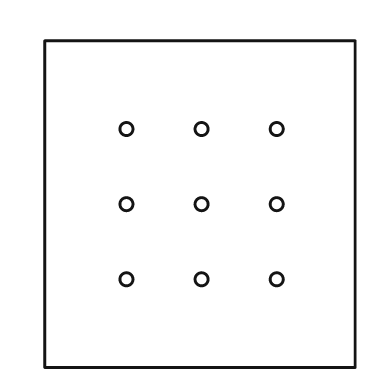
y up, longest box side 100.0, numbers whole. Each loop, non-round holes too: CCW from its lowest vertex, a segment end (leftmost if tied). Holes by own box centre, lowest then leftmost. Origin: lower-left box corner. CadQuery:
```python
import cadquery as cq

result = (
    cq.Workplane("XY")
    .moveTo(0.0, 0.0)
    .lineTo(95.0, 0.0)
    .lineTo(95.0, 100.0)
    .lineTo(0.0, 100.0)
    .close()
    .moveTo(25.0, 27.0)
    .circle(2.0)
    .moveTo(48.0, 27.0)
    .circle(2.0)
    .moveTo(71.0, 27.0)
    .circle(2.0)
    .moveTo(25.0, 50.0)
    .circle(2.0)
    .moveTo(48.0, 50.0)
    .circle(2.0)
    .moveTo(71.0, 50.0)
    .circle(2.0)
    .moveTo(25.0, 73.0)
    .circle(2.0)
    .moveTo(48.0, 73.0)
    .circle(2.0)
    .moveTo(71.0, 73.0)
    .circle(2.0)
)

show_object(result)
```